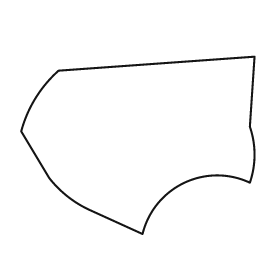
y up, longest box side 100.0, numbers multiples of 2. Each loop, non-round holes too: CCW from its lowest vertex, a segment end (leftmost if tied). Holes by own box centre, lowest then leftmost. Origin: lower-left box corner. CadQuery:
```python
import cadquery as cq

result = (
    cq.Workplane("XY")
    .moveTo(52.0, 0.0)
    .threePointArc((70.0, 22.0), (98.0, 22.0))
    .threePointArc((100.0, 34.0), (98.0, 46.0))
    .lineTo(100.0, 76.0)
    .lineTo(16.0, 70.0)
    .threePointArc((6.0, 58.0), (0.0, 44.0))
    .lineTo(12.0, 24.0)
    .threePointArc((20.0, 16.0), (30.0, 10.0))
    .close()
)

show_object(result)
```